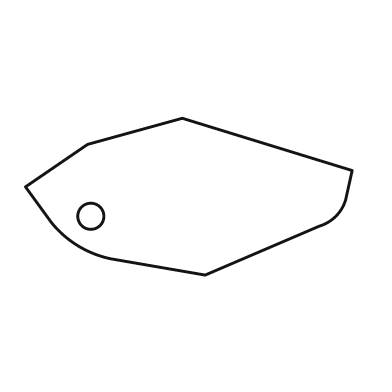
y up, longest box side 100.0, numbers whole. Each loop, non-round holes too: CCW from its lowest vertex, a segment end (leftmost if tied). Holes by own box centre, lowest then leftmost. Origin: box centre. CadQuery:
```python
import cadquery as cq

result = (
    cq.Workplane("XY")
    .moveTo(5.0, -24.0)
    .lineTo(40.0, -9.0)
    .threePointArc((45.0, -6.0), (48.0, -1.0))
    .lineTo(50.0, 8.0)
    .lineTo(-2.0, 24.0)
    .lineTo(-31.0, 16.0)
    .lineTo(-50.0, 3.0)
    .lineTo(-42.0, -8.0)
    .threePointArc((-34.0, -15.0), (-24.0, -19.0))
    .close()
    .moveTo(-30.0, -6.0)
    .circle(4.0)
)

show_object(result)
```